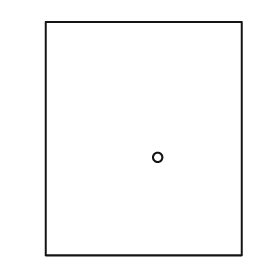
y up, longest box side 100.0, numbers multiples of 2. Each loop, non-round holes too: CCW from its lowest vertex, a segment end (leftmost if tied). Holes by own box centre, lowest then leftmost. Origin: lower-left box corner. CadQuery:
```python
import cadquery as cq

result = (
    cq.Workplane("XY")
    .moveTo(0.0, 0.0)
    .lineTo(84.0, 0.0)
    .lineTo(84.0, 100.0)
    .lineTo(0.0, 100.0)
    .close()
    .moveTo(48.0, 42.0)
    .circle(2.0)
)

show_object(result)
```